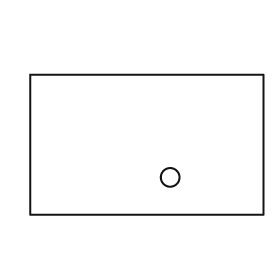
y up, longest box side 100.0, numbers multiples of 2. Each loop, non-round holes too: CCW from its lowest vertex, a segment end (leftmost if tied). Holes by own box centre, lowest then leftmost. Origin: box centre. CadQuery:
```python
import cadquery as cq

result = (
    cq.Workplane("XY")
    .moveTo(-50.0, -30.0)
    .lineTo(50.0, -30.0)
    .lineTo(50.0, 30.0)
    .lineTo(-50.0, 30.0)
    .close()
    .moveTo(10.0, -14.0)
    .circle(4.0)
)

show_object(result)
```